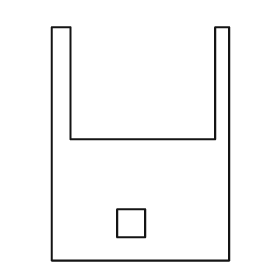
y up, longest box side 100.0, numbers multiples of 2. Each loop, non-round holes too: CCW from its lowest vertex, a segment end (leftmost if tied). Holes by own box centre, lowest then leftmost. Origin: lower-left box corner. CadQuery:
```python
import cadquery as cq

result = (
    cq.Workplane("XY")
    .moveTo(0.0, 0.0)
    .lineTo(76.0, 0.0)
    .lineTo(76.0, 100.0)
    .lineTo(70.0, 100.0)
    .lineTo(70.0, 52.0)
    .lineTo(8.0, 52.0)
    .lineTo(8.0, 100.0)
    .lineTo(0.0, 100.0)
    .close()
    .moveTo(28.0, 10.0)
    .lineTo(40.0, 10.0)
    .lineTo(40.0, 22.0)
    .lineTo(28.0, 22.0)
    .close()
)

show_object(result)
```